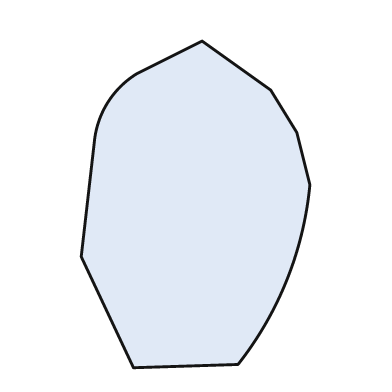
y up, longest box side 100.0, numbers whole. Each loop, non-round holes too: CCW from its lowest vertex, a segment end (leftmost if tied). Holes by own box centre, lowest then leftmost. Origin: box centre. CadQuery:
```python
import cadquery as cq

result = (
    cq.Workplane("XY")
    .moveTo(-19.0, -50.0)
    .lineTo(13.0, -49.0)
    .threePointArc((28.0, -23.0), (35.0, 6.0))
    .lineTo(31.0, 22.0)
    .lineTo(23.0, 35.0)
    .lineTo(2.0, 50.0)
    .lineTo(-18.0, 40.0)
    .threePointArc((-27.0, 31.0), (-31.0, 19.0))
    .lineTo(-35.0, -16.0)
    .close()
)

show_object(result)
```